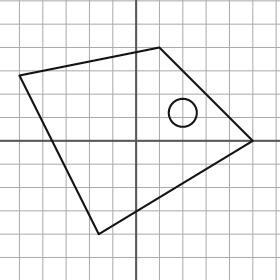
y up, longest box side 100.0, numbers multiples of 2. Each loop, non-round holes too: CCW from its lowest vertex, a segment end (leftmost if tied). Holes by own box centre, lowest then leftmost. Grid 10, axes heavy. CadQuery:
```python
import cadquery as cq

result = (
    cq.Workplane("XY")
    .moveTo(-16.0, -40.0)
    .lineTo(50.0, 0.0)
    .lineTo(10.0, 40.0)
    .lineTo(-50.0, 28.0)
    .close()
    .moveTo(20.0, 12.0)
    .circle(6.0)
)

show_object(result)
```